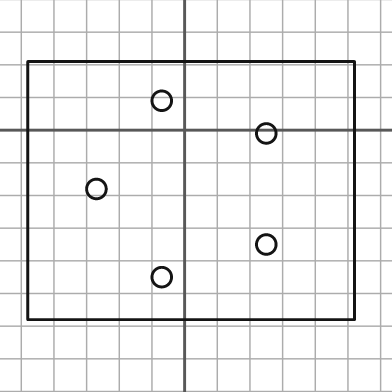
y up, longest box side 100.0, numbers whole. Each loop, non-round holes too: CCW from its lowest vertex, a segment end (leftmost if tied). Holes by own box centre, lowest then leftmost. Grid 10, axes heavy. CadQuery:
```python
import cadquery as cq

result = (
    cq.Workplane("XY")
    .moveTo(-48.0, -58.0)
    .lineTo(52.0, -58.0)
    .lineTo(52.0, 21.0)
    .lineTo(-48.0, 21.0)
    .close()
    .moveTo(-7.0, -45.0)
    .circle(3.0)
    .moveTo(25.0, -35.0)
    .circle(3.0)
    .moveTo(-27.0, -18.0)
    .circle(3.0)
    .moveTo(25.0, -1.0)
    .circle(3.0)
    .moveTo(-7.0, 9.0)
    .circle(3.0)
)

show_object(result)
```